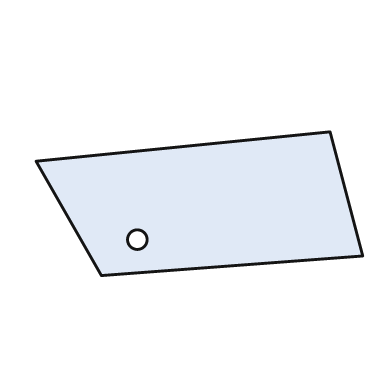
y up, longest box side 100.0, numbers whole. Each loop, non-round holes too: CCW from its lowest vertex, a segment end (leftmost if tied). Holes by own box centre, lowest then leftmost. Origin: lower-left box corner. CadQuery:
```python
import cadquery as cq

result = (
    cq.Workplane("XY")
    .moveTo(20.0, 0.0)
    .lineTo(100.0, 6.0)
    .lineTo(90.0, 44.0)
    .lineTo(0.0, 35.0)
    .close()
    .moveTo(31.0, 11.0)
    .circle(3.0)
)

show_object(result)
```